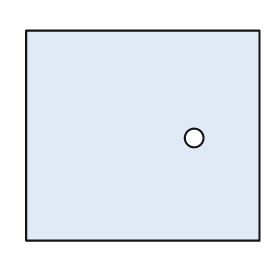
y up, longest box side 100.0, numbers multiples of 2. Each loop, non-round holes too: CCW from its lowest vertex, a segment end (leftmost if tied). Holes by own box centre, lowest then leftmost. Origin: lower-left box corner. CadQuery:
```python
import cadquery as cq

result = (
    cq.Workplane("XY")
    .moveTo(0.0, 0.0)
    .lineTo(100.0, 0.0)
    .lineTo(100.0, 90.0)
    .lineTo(0.0, 90.0)
    .close()
    .moveTo(72.0, 44.0)
    .circle(4.0)
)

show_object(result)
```